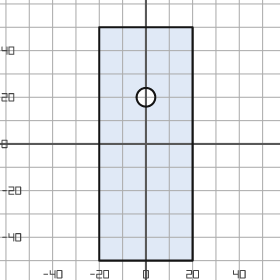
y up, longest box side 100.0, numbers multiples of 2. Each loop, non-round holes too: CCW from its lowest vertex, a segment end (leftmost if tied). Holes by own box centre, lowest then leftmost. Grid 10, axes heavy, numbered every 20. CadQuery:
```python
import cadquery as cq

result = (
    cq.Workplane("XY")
    .moveTo(-20.0, -50.0)
    .lineTo(20.0, -50.0)
    .lineTo(20.0, 50.0)
    .lineTo(-20.0, 50.0)
    .close()
    .moveTo(0.0, 20.0)
    .circle(4.0)
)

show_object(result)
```